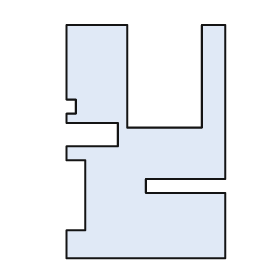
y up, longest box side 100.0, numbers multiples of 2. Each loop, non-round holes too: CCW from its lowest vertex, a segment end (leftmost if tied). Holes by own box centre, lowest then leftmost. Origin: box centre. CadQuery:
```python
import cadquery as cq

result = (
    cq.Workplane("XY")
    .moveTo(-34.0, -50.0)
    .lineTo(34.0, -50.0)
    .lineTo(34.0, -22.0)
    .lineTo(0.0, -22.0)
    .lineTo(0.0, -16.0)
    .lineTo(34.0, -16.0)
    .lineTo(34.0, 50.0)
    .lineTo(24.0, 50.0)
    .lineTo(24.0, 6.0)
    .lineTo(-8.0, 6.0)
    .lineTo(-8.0, 50.0)
    .lineTo(-34.0, 50.0)
    .lineTo(-34.0, 18.0)
    .lineTo(-30.0, 18.0)
    .lineTo(-30.0, 12.0)
    .lineTo(-34.0, 12.0)
    .lineTo(-34.0, 8.0)
    .lineTo(-12.0, 8.0)
    .lineTo(-12.0, -2.0)
    .lineTo(-34.0, -2.0)
    .lineTo(-34.0, -8.0)
    .lineTo(-26.0, -8.0)
    .lineTo(-26.0, -38.0)
    .lineTo(-34.0, -38.0)
    .close()
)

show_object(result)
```